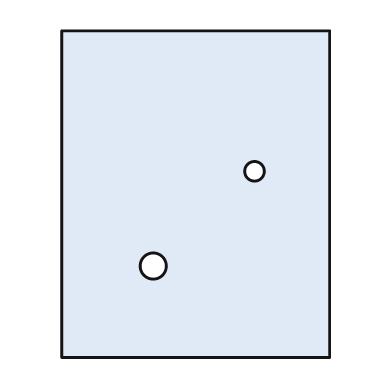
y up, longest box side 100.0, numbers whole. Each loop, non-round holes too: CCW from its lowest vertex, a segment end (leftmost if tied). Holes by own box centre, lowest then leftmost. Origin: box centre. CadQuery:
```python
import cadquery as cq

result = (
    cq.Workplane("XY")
    .moveTo(-41.0, -50.0)
    .lineTo(41.0, -50.0)
    .lineTo(41.0, 50.0)
    .lineTo(-41.0, 50.0)
    .close()
    .moveTo(-13.0, -22.0)
    .circle(4.0)
    .moveTo(18.0, 7.0)
    .circle(3.0)
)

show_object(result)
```